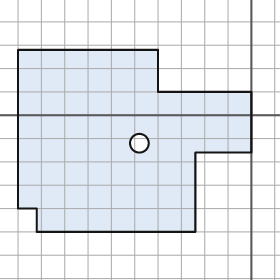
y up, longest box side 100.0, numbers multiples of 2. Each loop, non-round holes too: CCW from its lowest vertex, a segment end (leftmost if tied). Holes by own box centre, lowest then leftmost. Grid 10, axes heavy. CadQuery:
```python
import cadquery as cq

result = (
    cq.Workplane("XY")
    .moveTo(-92.0, -50.0)
    .lineTo(-24.0, -50.0)
    .lineTo(-24.0, -16.0)
    .lineTo(0.0, -16.0)
    .lineTo(0.0, 10.0)
    .lineTo(-40.0, 10.0)
    .lineTo(-40.0, 28.0)
    .lineTo(-100.0, 28.0)
    .lineTo(-100.0, -40.0)
    .lineTo(-92.0, -40.0)
    .close()
    .moveTo(-48.0, -12.0)
    .circle(4.0)
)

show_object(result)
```